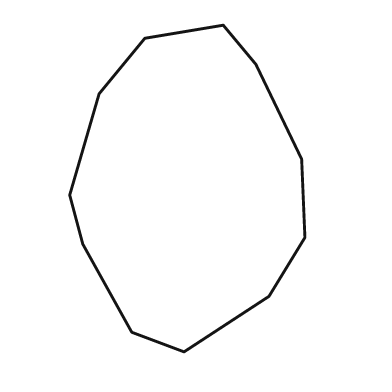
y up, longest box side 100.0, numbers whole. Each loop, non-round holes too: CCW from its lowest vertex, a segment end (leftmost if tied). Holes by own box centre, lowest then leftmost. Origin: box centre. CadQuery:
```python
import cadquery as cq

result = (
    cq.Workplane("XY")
    .moveTo(-1.0, -50.0)
    .lineTo(25.0, -33.0)
    .lineTo(36.0, -15.0)
    .lineTo(35.0, 9.0)
    .lineTo(21.0, 38.0)
    .lineTo(11.0, 50.0)
    .lineTo(-13.0, 46.0)
    .lineTo(-27.0, 29.0)
    .lineTo(-36.0, -2.0)
    .lineTo(-32.0, -17.0)
    .lineTo(-17.0, -44.0)
    .close()
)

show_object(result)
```